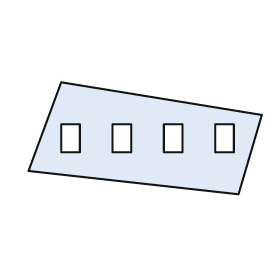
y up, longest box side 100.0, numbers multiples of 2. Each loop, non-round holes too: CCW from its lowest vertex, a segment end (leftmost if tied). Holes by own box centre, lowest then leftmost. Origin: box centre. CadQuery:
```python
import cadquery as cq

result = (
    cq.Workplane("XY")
    .moveTo(40.0, -24.0)
    .lineTo(50.0, 10.0)
    .lineTo(-36.0, 24.0)
    .lineTo(-50.0, -14.0)
    .close()
    .moveTo(-36.0, -6.0)
    .lineTo(-28.0, -6.0)
    .lineTo(-28.0, 6.0)
    .lineTo(-36.0, 6.0)
    .close()
    .moveTo(-14.0, -6.0)
    .lineTo(-6.0, -6.0)
    .lineTo(-6.0, 6.0)
    .lineTo(-14.0, 6.0)
    .close()
    .moveTo(8.0, -6.0)
    .lineTo(16.0, -6.0)
    .lineTo(16.0, 6.0)
    .lineTo(8.0, 6.0)
    .close()
    .moveTo(30.0, -6.0)
    .lineTo(38.0, -6.0)
    .lineTo(38.0, 6.0)
    .lineTo(30.0, 6.0)
    .close()
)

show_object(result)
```